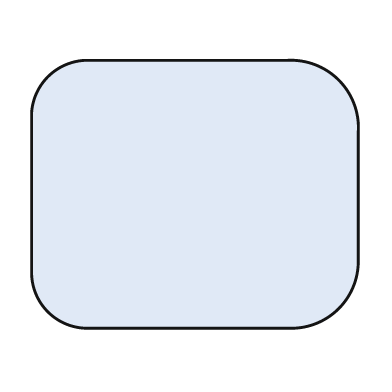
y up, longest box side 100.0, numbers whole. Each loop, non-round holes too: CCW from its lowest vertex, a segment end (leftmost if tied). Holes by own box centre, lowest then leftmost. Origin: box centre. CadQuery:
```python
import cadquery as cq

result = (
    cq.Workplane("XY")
    .moveTo(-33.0, -41.0)
    .lineTo(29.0, -41.0)
    .threePointArc((44.0, -35.0), (50.0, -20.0))
    .lineTo(50.0, 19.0)
    .threePointArc((44.0, 35.0), (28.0, 41.0))
    .lineTo(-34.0, 41.0)
    .threePointArc((-45.0, 36.0), (-50.0, 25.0))
    .lineTo(-50.0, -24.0)
    .threePointArc((-45.0, -36.0), (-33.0, -41.0))
    .close()
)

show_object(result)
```